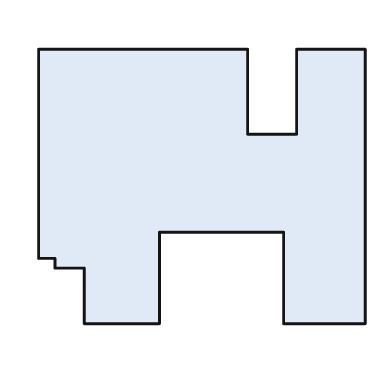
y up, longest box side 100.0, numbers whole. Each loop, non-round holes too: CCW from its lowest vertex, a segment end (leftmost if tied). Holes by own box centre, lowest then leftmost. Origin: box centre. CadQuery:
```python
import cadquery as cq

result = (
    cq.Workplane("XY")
    .moveTo(-36.0, -42.0)
    .lineTo(-13.0, -42.0)
    .lineTo(-13.0, -14.0)
    .lineTo(25.0, -14.0)
    .lineTo(25.0, -42.0)
    .lineTo(50.0, -42.0)
    .lineTo(50.0, 42.0)
    .lineTo(29.0, 42.0)
    .lineTo(29.0, 16.0)
    .lineTo(14.0, 16.0)
    .lineTo(14.0, 42.0)
    .lineTo(-50.0, 42.0)
    .lineTo(-50.0, -22.0)
    .lineTo(-45.0, -22.0)
    .lineTo(-45.0, -25.0)
    .lineTo(-36.0, -25.0)
    .close()
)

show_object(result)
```